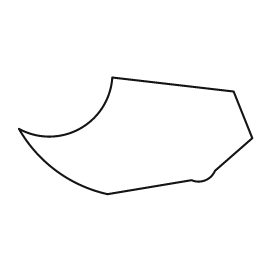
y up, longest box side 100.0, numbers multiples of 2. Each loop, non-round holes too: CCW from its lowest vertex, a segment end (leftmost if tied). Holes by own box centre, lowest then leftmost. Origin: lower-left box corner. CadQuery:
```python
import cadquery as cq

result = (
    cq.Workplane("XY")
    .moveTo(38.0, 0.0)
    .lineTo(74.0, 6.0)
    .threePointArc((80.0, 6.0), (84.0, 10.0))
    .lineTo(100.0, 24.0)
    .lineTo(92.0, 44.0)
    .lineTo(40.0, 50.0)
    .threePointArc((26.0, 28.0), (0.0, 28.0))
    .threePointArc((16.0, 10.0), (38.0, 0.0))
    .close()
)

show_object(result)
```